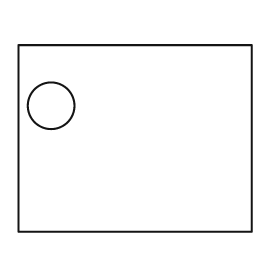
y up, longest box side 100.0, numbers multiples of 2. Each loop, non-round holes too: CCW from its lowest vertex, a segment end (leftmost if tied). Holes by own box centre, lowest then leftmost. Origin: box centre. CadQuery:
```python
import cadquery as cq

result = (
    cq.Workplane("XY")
    .moveTo(-50.0, -40.0)
    .lineTo(50.0, -40.0)
    .lineTo(50.0, 40.0)
    .lineTo(-50.0, 40.0)
    .close()
    .moveTo(-36.0, 14.0)
    .circle(10.0)
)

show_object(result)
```